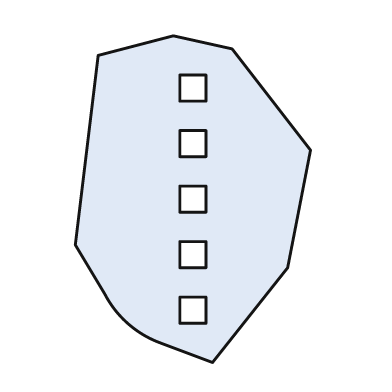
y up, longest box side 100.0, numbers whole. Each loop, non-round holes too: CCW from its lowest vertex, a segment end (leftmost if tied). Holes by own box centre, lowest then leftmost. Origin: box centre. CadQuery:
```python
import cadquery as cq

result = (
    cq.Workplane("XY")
    .moveTo(6.0, -50.0)
    .lineTo(29.0, -21.0)
    .lineTo(36.0, 15.0)
    .lineTo(12.0, 46.0)
    .lineTo(-6.0, 50.0)
    .lineTo(-29.0, 44.0)
    .lineTo(-36.0, -14.0)
    .lineTo(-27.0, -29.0)
    .threePointArc((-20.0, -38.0), (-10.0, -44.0))
    .close()
    .moveTo(-4.0, -38.0)
    .lineTo(4.0, -38.0)
    .lineTo(4.0, -30.0)
    .lineTo(-4.0, -30.0)
    .close()
    .moveTo(-4.0, -21.0)
    .lineTo(4.0, -21.0)
    .lineTo(4.0, -13.0)
    .lineTo(-4.0, -13.0)
    .close()
    .moveTo(-4.0, -4.0)
    .lineTo(4.0, -4.0)
    .lineTo(4.0, 4.0)
    .lineTo(-4.0, 4.0)
    .close()
    .moveTo(-4.0, 13.0)
    .lineTo(4.0, 13.0)
    .lineTo(4.0, 21.0)
    .lineTo(-4.0, 21.0)
    .close()
    .moveTo(-4.0, 30.0)
    .lineTo(4.0, 30.0)
    .lineTo(4.0, 38.0)
    .lineTo(-4.0, 38.0)
    .close()
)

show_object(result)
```